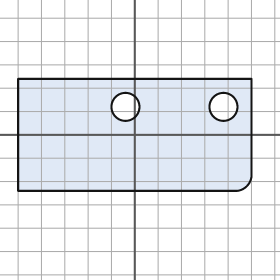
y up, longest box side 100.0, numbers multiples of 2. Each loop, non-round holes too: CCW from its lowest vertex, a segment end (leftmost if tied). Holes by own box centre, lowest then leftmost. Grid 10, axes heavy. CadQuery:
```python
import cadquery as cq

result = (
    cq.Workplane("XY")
    .moveTo(-50.0, -24.0)
    .lineTo(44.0, -24.0)
    .threePointArc((48.0, -22.0), (50.0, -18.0))
    .lineTo(50.0, 24.0)
    .lineTo(-50.0, 24.0)
    .close()
    .moveTo(-4.0, 12.0)
    .circle(6.0)
    .moveTo(38.0, 12.0)
    .circle(6.0)
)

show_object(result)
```